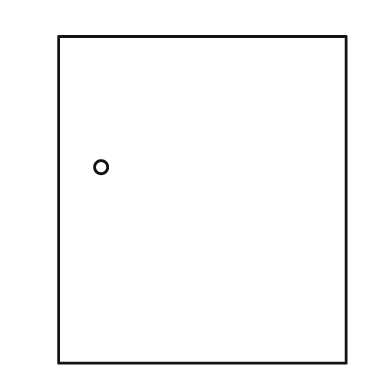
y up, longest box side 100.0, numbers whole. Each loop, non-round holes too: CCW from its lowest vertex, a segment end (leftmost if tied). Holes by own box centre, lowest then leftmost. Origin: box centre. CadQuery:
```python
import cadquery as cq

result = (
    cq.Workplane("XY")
    .moveTo(-44.0, -50.0)
    .lineTo(44.0, -50.0)
    .lineTo(44.0, 50.0)
    .lineTo(-44.0, 50.0)
    .close()
    .moveTo(-31.0, 10.0)
    .circle(2.0)
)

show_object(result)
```